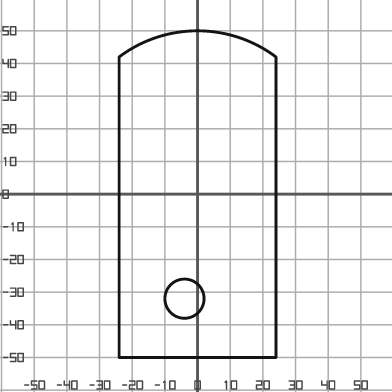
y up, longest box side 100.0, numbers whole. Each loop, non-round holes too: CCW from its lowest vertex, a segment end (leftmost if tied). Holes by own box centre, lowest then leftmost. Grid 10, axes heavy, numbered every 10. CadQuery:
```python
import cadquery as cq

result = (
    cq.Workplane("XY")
    .moveTo(-24.0, -50.0)
    .lineTo(24.0, -50.0)
    .lineTo(24.0, 42.0)
    .threePointArc((0.0, 50.0), (-24.0, 42.0))
    .close()
    .moveTo(-4.0, -32.0)
    .circle(6.0)
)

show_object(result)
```